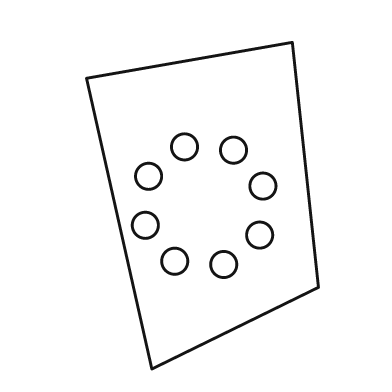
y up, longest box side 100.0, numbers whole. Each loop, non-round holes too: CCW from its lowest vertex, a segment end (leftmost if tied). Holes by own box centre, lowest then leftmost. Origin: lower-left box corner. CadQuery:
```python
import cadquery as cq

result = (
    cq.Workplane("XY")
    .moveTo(20.0, 0.0)
    .lineTo(71.0, 25.0)
    .lineTo(63.0, 100.0)
    .lineTo(0.0, 89.0)
    .close()
    .moveTo(42.0, 32.0)
    .circle(4.0)
    .moveTo(27.0, 33.0)
    .circle(4.0)
    .moveTo(53.0, 41.0)
    .circle(4.0)
    .moveTo(18.0, 44.0)
    .circle(4.0)
    .moveTo(54.0, 56.0)
    .circle(4.0)
    .moveTo(19.0, 59.0)
    .circle(4.0)
    .moveTo(45.0, 67.0)
    .circle(4.0)
    .moveTo(30.0, 68.0)
    .circle(4.0)
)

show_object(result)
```